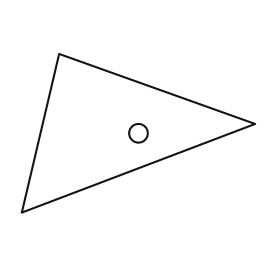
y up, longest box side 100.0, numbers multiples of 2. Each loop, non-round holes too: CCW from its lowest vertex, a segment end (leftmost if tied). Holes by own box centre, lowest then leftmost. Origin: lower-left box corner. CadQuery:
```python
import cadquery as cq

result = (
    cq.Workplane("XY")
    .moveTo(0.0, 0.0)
    .lineTo(100.0, 38.0)
    .lineTo(16.0, 68.0)
    .close()
    .moveTo(50.0, 34.0)
    .circle(4.0)
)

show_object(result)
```